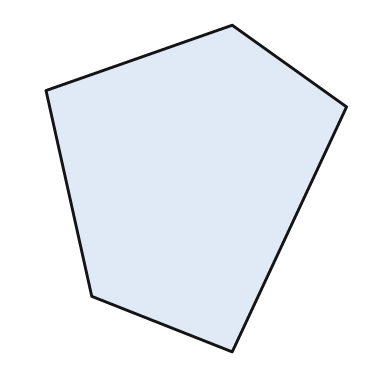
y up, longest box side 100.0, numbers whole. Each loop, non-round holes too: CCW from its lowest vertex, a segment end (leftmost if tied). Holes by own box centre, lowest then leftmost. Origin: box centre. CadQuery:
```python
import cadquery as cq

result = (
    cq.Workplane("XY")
    .moveTo(11.0, -50.0)
    .lineTo(46.0, 25.0)
    .lineTo(11.0, 50.0)
    .lineTo(-46.0, 30.0)
    .lineTo(-32.0, -33.0)
    .close()
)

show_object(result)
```